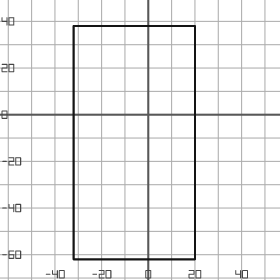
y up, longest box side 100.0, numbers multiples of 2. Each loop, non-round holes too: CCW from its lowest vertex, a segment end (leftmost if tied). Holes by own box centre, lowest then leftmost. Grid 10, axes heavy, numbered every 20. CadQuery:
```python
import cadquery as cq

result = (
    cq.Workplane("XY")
    .moveTo(-32.0, -62.0)
    .lineTo(20.0, -62.0)
    .lineTo(20.0, 38.0)
    .lineTo(-32.0, 38.0)
    .close()
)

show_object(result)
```